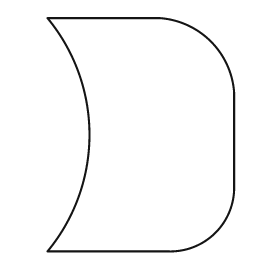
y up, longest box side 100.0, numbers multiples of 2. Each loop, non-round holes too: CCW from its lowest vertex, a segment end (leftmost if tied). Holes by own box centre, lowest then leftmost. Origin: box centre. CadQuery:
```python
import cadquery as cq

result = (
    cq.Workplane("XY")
    .moveTo(-40.0, -50.0)
    .lineTo(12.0, -50.0)
    .threePointArc((32.0, -42.0), (40.0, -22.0))
    .lineTo(40.0, 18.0)
    .threePointArc((30.0, 40.0), (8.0, 50.0))
    .lineTo(-40.0, 50.0)
    .threePointArc((-22.0, 0.0), (-40.0, -50.0))
    .close()
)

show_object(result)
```